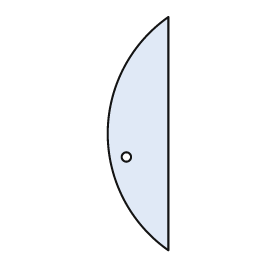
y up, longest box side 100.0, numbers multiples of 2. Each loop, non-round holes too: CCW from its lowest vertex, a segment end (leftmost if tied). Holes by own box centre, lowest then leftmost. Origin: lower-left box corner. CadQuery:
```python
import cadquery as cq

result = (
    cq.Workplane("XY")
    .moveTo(26.0, 0.0)
    .lineTo(26.0, 100.0)
    .threePointArc((0.0, 50.0), (26.0, 0.0))
    .close()
    .moveTo(8.0, 40.0)
    .circle(2.0)
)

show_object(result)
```